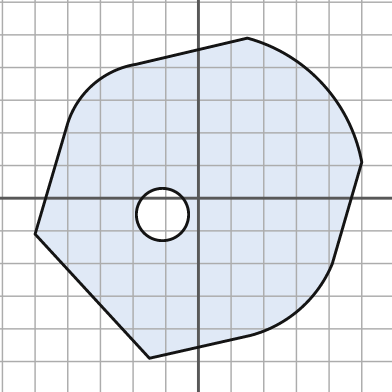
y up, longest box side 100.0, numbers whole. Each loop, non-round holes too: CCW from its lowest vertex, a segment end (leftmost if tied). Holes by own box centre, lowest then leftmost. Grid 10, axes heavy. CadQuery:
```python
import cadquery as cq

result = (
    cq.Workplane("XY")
    .moveTo(-15.0, -49.0)
    .lineTo(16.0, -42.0)
    .threePointArc((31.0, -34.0), (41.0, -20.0))
    .lineTo(50.0, 11.0)
    .threePointArc((38.0, 35.0), (15.0, 49.0))
    .lineTo(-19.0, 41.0)
    .threePointArc((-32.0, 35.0), (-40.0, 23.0))
    .lineTo(-50.0, -11.0)
    .close()
    .moveTo(-11.0, -5.0)
    .circle(8.0)
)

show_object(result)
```